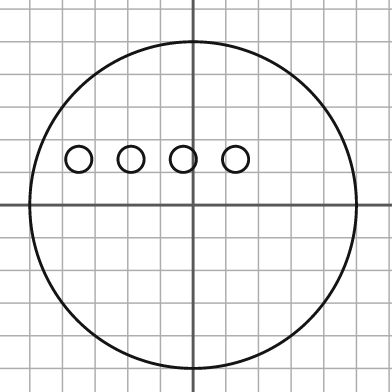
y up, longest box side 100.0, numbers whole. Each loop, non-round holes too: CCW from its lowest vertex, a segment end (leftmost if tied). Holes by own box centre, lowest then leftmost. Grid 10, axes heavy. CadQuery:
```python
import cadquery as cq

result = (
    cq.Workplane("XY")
    .moveTo(0.0, 0.0)
    .circle(50.0)
    .moveTo(-35.0, 14.0)
    .circle(4.0)
    .moveTo(-19.0, 14.0)
    .circle(4.0)
    .moveTo(-3.0, 14.0)
    .circle(4.0)
    .moveTo(13.0, 14.0)
    .circle(4.0)
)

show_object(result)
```